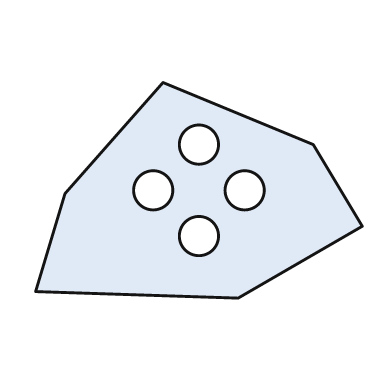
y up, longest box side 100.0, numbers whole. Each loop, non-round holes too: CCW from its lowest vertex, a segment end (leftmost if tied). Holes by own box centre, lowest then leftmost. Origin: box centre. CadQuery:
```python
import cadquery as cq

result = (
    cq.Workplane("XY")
    .moveTo(12.0, -33.0)
    .lineTo(50.0, -11.0)
    .lineTo(35.0, 14.0)
    .lineTo(-11.0, 33.0)
    .lineTo(-41.0, -1.0)
    .lineTo(-50.0, -31.0)
    .close()
    .moveTo(0.0, -14.0)
    .circle(6.0)
    .moveTo(-14.0, 0.0)
    .circle(6.0)
    .moveTo(14.0, 0.0)
    .circle(6.0)
    .moveTo(0.0, 14.0)
    .circle(6.0)
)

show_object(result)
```